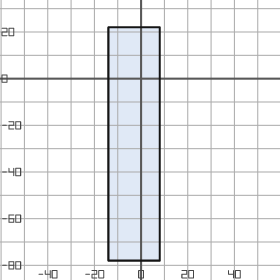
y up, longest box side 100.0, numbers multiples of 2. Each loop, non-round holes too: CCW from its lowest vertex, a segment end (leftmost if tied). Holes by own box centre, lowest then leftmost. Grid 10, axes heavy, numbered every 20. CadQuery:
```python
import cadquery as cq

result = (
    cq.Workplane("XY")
    .moveTo(-14.0, -78.0)
    .lineTo(8.0, -78.0)
    .lineTo(8.0, 22.0)
    .lineTo(-14.0, 22.0)
    .close()
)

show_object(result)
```